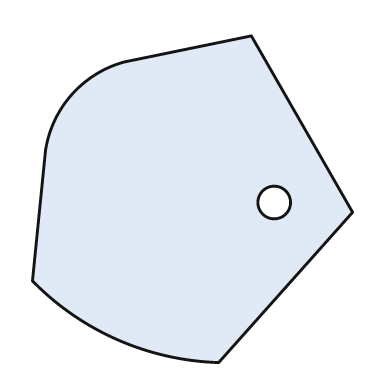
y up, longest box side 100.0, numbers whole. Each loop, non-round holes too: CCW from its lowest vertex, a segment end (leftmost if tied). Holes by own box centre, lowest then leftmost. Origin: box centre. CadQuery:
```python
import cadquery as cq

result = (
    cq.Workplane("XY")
    .moveTo(8.0, -50.0)
    .lineTo(49.0, -4.0)
    .lineTo(18.0, 50.0)
    .lineTo(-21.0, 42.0)
    .threePointArc((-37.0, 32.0), (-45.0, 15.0))
    .lineTo(-49.0, -25.0)
    .threePointArc((-23.0, -43.0), (8.0, -50.0))
    .close()
    .moveTo(25.0, -1.0)
    .circle(5.0)
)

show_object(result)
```